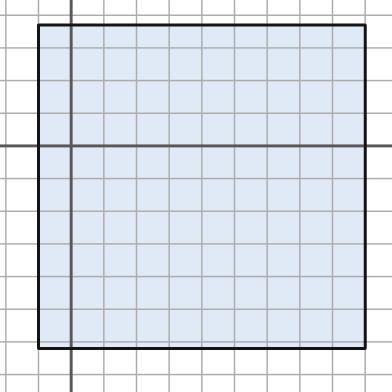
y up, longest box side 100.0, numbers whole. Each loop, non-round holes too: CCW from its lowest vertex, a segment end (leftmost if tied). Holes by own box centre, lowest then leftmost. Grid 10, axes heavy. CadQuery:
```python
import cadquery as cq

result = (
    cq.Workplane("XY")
    .moveTo(-10.0, -62.0)
    .lineTo(90.0, -62.0)
    .lineTo(90.0, 37.0)
    .lineTo(-10.0, 37.0)
    .close()
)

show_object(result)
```